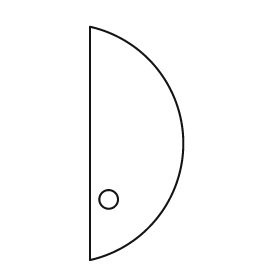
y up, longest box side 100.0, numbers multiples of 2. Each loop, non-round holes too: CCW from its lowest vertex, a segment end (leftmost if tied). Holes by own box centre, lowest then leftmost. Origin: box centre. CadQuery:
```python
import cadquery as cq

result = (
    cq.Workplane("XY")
    .moveTo(-20.0, -50.0)
    .threePointArc((20.0, 0.0), (-20.0, 50.0))
    .close()
    .moveTo(-12.0, -24.0)
    .circle(4.0)
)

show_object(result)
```